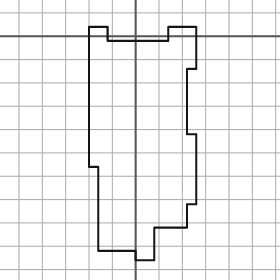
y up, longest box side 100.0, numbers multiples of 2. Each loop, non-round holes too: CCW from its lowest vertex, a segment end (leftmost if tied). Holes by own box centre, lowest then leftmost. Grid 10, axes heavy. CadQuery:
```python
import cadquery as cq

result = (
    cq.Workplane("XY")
    .moveTo(0.0, -96.0)
    .lineTo(8.0, -96.0)
    .lineTo(8.0, -82.0)
    .lineTo(22.0, -82.0)
    .lineTo(22.0, -72.0)
    .lineTo(26.0, -72.0)
    .lineTo(26.0, -42.0)
    .lineTo(22.0, -42.0)
    .lineTo(22.0, -14.0)
    .lineTo(26.0, -14.0)
    .lineTo(26.0, 4.0)
    .lineTo(14.0, 4.0)
    .lineTo(14.0, -2.0)
    .lineTo(-12.0, -2.0)
    .lineTo(-12.0, 4.0)
    .lineTo(-20.0, 4.0)
    .lineTo(-20.0, -56.0)
    .lineTo(-16.0, -56.0)
    .lineTo(-16.0, -92.0)
    .lineTo(0.0, -92.0)
    .close()
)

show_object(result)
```